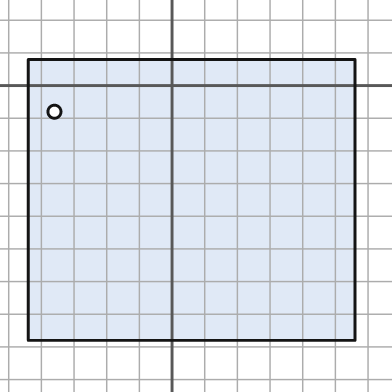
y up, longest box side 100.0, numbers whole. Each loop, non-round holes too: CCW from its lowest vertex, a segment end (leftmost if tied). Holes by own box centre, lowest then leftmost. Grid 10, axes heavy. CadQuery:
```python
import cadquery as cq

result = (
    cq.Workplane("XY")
    .moveTo(-44.0, -78.0)
    .lineTo(56.0, -78.0)
    .lineTo(56.0, 8.0)
    .lineTo(-44.0, 8.0)
    .close()
    .moveTo(-36.0, -8.0)
    .circle(2.0)
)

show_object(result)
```